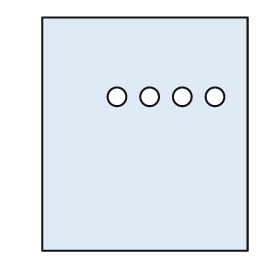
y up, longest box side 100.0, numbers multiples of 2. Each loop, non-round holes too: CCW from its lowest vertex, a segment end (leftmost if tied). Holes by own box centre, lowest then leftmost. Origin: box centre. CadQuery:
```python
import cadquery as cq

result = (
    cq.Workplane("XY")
    .moveTo(-44.0, -50.0)
    .lineTo(44.0, -50.0)
    .lineTo(44.0, 50.0)
    .lineTo(-44.0, 50.0)
    .close()
    .moveTo(-12.0, 16.0)
    .circle(4.0)
    .moveTo(2.0, 16.0)
    .circle(4.0)
    .moveTo(16.0, 16.0)
    .circle(4.0)
    .moveTo(30.0, 16.0)
    .circle(4.0)
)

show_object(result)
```